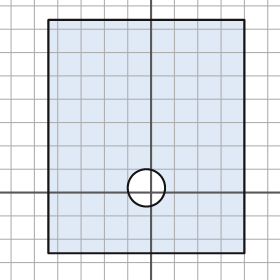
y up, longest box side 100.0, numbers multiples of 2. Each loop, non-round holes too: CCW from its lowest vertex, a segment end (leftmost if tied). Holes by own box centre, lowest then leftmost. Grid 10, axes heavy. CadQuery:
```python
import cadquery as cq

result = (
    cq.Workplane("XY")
    .moveTo(-44.0, -26.0)
    .lineTo(40.0, -26.0)
    .lineTo(40.0, 74.0)
    .lineTo(-44.0, 74.0)
    .close()
    .moveTo(-2.0, 2.0)
    .circle(8.0)
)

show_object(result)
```